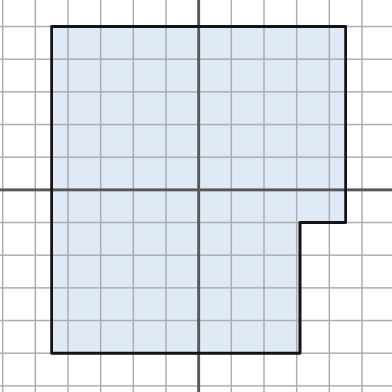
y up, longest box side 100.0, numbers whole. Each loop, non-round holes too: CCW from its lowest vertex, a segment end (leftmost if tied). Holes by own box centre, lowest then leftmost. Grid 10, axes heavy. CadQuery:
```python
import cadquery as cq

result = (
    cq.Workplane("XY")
    .moveTo(-45.0, -50.0)
    .lineTo(31.0, -50.0)
    .lineTo(31.0, -10.0)
    .lineTo(45.0, -10.0)
    .lineTo(45.0, 50.0)
    .lineTo(-45.0, 50.0)
    .close()
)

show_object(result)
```